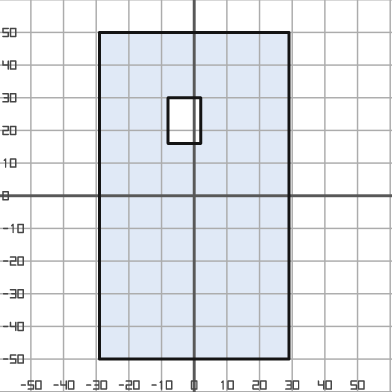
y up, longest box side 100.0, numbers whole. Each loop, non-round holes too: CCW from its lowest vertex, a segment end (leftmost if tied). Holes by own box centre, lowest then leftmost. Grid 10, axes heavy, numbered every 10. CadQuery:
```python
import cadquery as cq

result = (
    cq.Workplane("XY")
    .moveTo(-29.0, -50.0)
    .lineTo(29.0, -50.0)
    .lineTo(29.0, 50.0)
    .lineTo(-29.0, 50.0)
    .close()
    .moveTo(-8.0, 16.0)
    .lineTo(2.0, 16.0)
    .lineTo(2.0, 30.0)
    .lineTo(-8.0, 30.0)
    .close()
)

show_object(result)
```